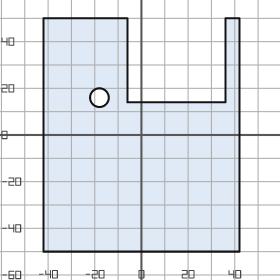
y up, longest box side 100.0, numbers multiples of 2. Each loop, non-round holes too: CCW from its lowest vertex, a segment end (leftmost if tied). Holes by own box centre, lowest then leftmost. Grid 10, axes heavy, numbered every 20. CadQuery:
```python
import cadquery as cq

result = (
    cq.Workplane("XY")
    .moveTo(-42.0, -50.0)
    .lineTo(42.0, -50.0)
    .lineTo(42.0, 50.0)
    .lineTo(36.0, 50.0)
    .lineTo(36.0, 14.0)
    .lineTo(-6.0, 14.0)
    .lineTo(-6.0, 50.0)
    .lineTo(-42.0, 50.0)
    .close()
    .moveTo(-18.0, 16.0)
    .circle(4.0)
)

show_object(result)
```